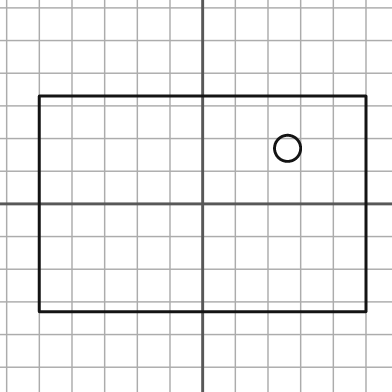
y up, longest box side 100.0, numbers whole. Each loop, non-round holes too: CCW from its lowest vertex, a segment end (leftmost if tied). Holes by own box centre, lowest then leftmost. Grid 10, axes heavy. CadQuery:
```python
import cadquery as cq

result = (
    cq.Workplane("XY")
    .moveTo(-50.0, -33.0)
    .lineTo(50.0, -33.0)
    .lineTo(50.0, 33.0)
    .lineTo(-50.0, 33.0)
    .close()
    .moveTo(26.0, 17.0)
    .circle(4.0)
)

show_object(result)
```